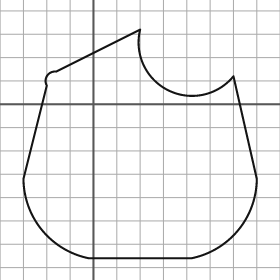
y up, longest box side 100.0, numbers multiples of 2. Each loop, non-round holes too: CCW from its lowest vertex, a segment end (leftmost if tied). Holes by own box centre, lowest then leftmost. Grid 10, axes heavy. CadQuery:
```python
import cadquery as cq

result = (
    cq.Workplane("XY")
    .moveTo(-2.0, -66.0)
    .lineTo(42.0, -66.0)
    .threePointArc((62.0, -54.0), (70.0, -32.0))
    .lineTo(60.0, 12.0)
    .threePointArc((32.0, 6.0), (20.0, 32.0))
    .lineTo(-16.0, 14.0)
    .threePointArc((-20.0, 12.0), (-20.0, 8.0))
    .lineTo(-30.0, -32.0)
    .threePointArc((-22.0, -54.0), (-2.0, -66.0))
    .close()
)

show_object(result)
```